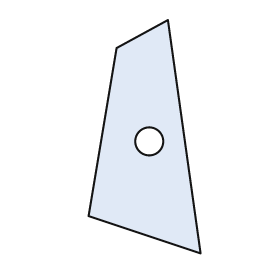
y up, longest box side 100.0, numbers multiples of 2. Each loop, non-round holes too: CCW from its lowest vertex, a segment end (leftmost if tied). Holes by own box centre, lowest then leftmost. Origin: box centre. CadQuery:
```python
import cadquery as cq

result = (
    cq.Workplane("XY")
    .moveTo(24.0, -50.0)
    .lineTo(10.0, 50.0)
    .lineTo(-12.0, 38.0)
    .lineTo(-24.0, -34.0)
    .close()
    .moveTo(2.0, -2.0)
    .circle(6.0)
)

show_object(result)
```